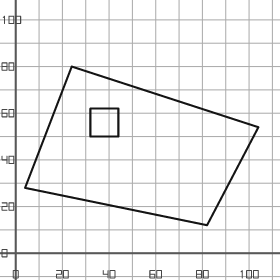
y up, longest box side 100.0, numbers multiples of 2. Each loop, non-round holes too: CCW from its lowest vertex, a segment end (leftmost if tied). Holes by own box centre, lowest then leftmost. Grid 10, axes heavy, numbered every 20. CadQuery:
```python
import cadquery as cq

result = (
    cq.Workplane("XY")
    .moveTo(82.0, 12.0)
    .lineTo(104.0, 54.0)
    .lineTo(24.0, 80.0)
    .lineTo(4.0, 28.0)
    .close()
    .moveTo(32.0, 50.0)
    .lineTo(44.0, 50.0)
    .lineTo(44.0, 62.0)
    .lineTo(32.0, 62.0)
    .close()
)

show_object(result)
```